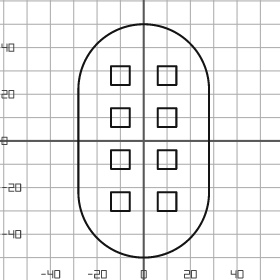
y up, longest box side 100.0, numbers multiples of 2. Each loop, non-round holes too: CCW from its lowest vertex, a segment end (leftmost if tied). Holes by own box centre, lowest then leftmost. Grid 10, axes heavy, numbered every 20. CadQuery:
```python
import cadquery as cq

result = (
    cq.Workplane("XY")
    .moveTo(-28.0, -22.0)
    .threePointArc((0.0, -50.0), (28.0, -22.0))
    .lineTo(28.0, 22.0)
    .threePointArc((0.0, 50.0), (-28.0, 22.0))
    .close()
    .moveTo(-14.0, -30.0)
    .lineTo(-6.0, -30.0)
    .lineTo(-6.0, -22.0)
    .lineTo(-14.0, -22.0)
    .close()
    .moveTo(6.0, -30.0)
    .lineTo(14.0, -30.0)
    .lineTo(14.0, -22.0)
    .lineTo(6.0, -22.0)
    .close()
    .moveTo(-14.0, -12.0)
    .lineTo(-6.0, -12.0)
    .lineTo(-6.0, -4.0)
    .lineTo(-14.0, -4.0)
    .close()
    .moveTo(6.0, -12.0)
    .lineTo(14.0, -12.0)
    .lineTo(14.0, -4.0)
    .lineTo(6.0, -4.0)
    .close()
    .moveTo(-14.0, 6.0)
    .lineTo(-6.0, 6.0)
    .lineTo(-6.0, 14.0)
    .lineTo(-14.0, 14.0)
    .close()
    .moveTo(6.0, 6.0)
    .lineTo(14.0, 6.0)
    .lineTo(14.0, 14.0)
    .lineTo(6.0, 14.0)
    .close()
    .moveTo(-14.0, 24.0)
    .lineTo(-6.0, 24.0)
    .lineTo(-6.0, 32.0)
    .lineTo(-14.0, 32.0)
    .close()
    .moveTo(6.0, 24.0)
    .lineTo(14.0, 24.0)
    .lineTo(14.0, 32.0)
    .lineTo(6.0, 32.0)
    .close()
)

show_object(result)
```